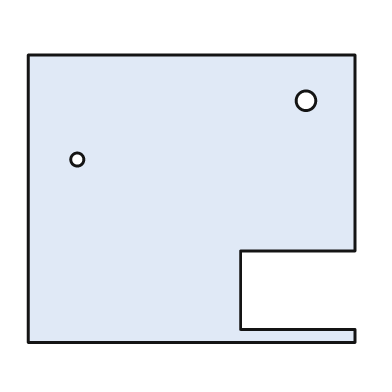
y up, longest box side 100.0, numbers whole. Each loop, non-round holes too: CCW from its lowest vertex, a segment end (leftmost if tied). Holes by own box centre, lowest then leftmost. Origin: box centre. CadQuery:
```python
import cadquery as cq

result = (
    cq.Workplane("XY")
    .moveTo(-50.0, -44.0)
    .lineTo(50.0, -44.0)
    .lineTo(50.0, -40.0)
    .lineTo(15.0, -40.0)
    .lineTo(15.0, -16.0)
    .lineTo(50.0, -16.0)
    .lineTo(50.0, 44.0)
    .lineTo(-50.0, 44.0)
    .close()
    .moveTo(-35.0, 12.0)
    .circle(2.0)
    .moveTo(35.0, 30.0)
    .circle(3.0)
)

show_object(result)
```